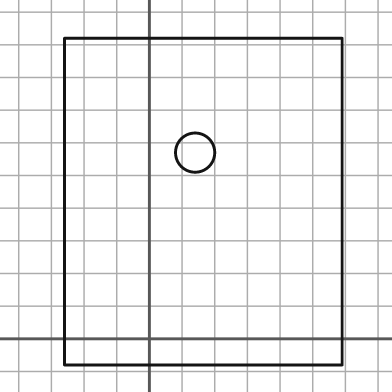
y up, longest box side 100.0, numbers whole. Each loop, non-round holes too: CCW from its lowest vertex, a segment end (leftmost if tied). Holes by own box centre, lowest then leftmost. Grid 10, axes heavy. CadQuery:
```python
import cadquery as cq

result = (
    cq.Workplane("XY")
    .moveTo(-26.0, -8.0)
    .lineTo(59.0, -8.0)
    .lineTo(59.0, 92.0)
    .lineTo(-26.0, 92.0)
    .close()
    .moveTo(14.0, 57.0)
    .circle(6.0)
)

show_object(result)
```